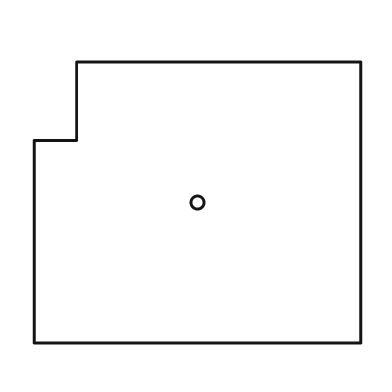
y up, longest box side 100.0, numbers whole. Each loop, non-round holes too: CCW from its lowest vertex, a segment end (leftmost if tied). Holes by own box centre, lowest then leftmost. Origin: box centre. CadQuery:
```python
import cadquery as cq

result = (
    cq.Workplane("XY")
    .moveTo(-50.0, -43.0)
    .lineTo(50.0, -43.0)
    .lineTo(50.0, 43.0)
    .lineTo(-37.0, 43.0)
    .lineTo(-37.0, 19.0)
    .lineTo(-50.0, 19.0)
    .close()
    .moveTo(0.0, 0.0)
    .circle(2.0)
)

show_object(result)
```